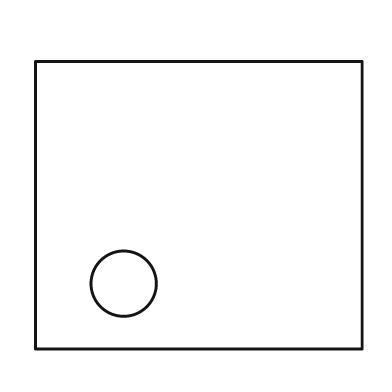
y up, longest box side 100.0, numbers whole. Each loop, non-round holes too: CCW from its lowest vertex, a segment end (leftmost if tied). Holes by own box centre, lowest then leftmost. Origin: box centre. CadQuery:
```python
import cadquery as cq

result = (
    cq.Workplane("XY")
    .moveTo(-50.0, -44.0)
    .lineTo(50.0, -44.0)
    .lineTo(50.0, 44.0)
    .lineTo(-50.0, 44.0)
    .close()
    .moveTo(-23.0, -24.0)
    .circle(10.0)
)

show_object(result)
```